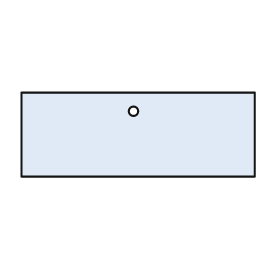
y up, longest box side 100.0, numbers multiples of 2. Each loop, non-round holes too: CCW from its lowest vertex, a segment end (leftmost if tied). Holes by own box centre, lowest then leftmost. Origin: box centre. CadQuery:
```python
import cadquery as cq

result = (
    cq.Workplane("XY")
    .moveTo(-50.0, -18.0)
    .lineTo(50.0, -18.0)
    .lineTo(50.0, 18.0)
    .lineTo(-50.0, 18.0)
    .close()
    .moveTo(-2.0, 10.0)
    .circle(2.0)
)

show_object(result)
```